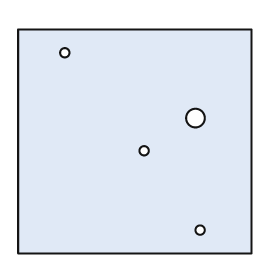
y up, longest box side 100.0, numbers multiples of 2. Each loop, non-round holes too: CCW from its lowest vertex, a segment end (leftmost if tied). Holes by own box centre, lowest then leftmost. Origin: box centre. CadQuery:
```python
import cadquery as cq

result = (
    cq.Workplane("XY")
    .moveTo(-50.0, -48.0)
    .lineTo(50.0, -48.0)
    .lineTo(50.0, 48.0)
    .lineTo(-50.0, 48.0)
    .close()
    .moveTo(28.0, -38.0)
    .circle(2.0)
    .moveTo(4.0, -4.0)
    .circle(2.0)
    .moveTo(26.0, 10.0)
    .circle(4.0)
    .moveTo(-30.0, 38.0)
    .circle(2.0)
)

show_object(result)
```